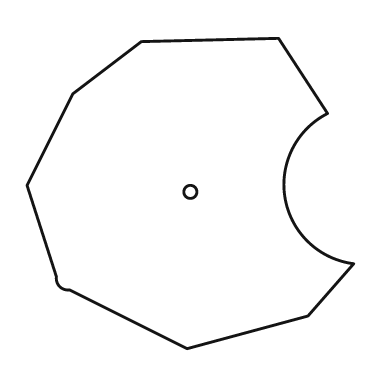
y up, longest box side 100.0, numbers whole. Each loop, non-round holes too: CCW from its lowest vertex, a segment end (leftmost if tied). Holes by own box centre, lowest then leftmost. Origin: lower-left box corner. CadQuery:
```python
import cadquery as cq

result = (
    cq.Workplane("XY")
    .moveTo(49.0, 0.0)
    .lineTo(86.0, 10.0)
    .lineTo(100.0, 26.0)
    .threePointArc((79.0, 46.0), (92.0, 72.0))
    .lineTo(77.0, 95.0)
    .lineTo(35.0, 94.0)
    .lineTo(14.0, 78.0)
    .lineTo(0.0, 50.0)
    .lineTo(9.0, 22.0)
    .threePointArc((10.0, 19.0), (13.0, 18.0))
    .close()
    .moveTo(50.0, 48.0)
    .circle(2.0)
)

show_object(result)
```